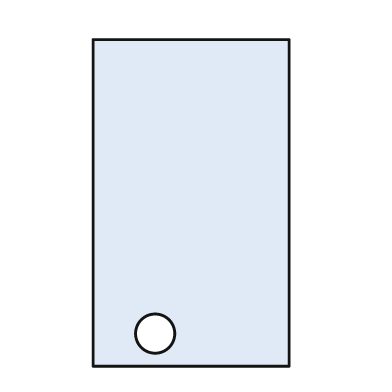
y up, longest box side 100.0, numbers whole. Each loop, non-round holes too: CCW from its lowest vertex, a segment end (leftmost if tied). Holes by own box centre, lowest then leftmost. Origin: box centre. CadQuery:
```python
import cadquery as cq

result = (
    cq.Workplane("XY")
    .moveTo(-30.0, -50.0)
    .lineTo(30.0, -50.0)
    .lineTo(30.0, 50.0)
    .lineTo(-30.0, 50.0)
    .close()
    .moveTo(-11.0, -40.0)
    .circle(6.0)
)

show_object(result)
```